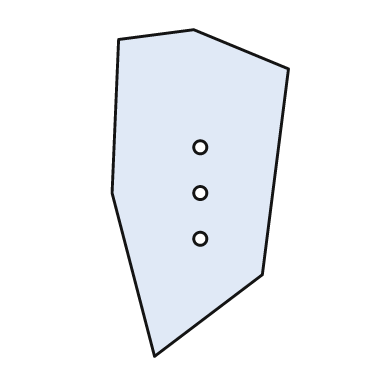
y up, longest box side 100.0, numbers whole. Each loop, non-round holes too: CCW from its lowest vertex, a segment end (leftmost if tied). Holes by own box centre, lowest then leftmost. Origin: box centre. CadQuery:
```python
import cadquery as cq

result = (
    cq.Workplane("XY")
    .moveTo(-14.0, -50.0)
    .lineTo(19.0, -25.0)
    .lineTo(27.0, 38.0)
    .lineTo(-2.0, 50.0)
    .lineTo(-25.0, 47.0)
    .lineTo(-27.0, 0.0)
    .close()
    .moveTo(0.0, -14.0)
    .circle(2.0)
    .moveTo(0.0, 0.0)
    .circle(2.0)
    .moveTo(0.0, 14.0)
    .circle(2.0)
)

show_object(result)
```